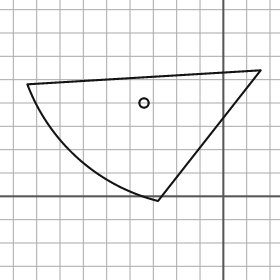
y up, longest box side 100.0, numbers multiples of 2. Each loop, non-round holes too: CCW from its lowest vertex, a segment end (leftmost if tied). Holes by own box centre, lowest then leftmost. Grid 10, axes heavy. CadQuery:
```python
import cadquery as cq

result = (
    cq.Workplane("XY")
    .moveTo(-28.0, -2.0)
    .lineTo(16.0, 54.0)
    .lineTo(-84.0, 48.0)
    .threePointArc((-62.0, 16.0), (-28.0, -2.0))
    .close()
    .moveTo(-34.0, 40.0)
    .circle(2.0)
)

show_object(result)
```